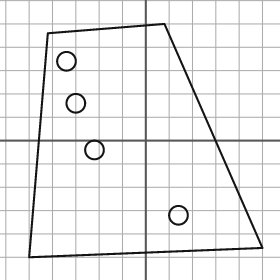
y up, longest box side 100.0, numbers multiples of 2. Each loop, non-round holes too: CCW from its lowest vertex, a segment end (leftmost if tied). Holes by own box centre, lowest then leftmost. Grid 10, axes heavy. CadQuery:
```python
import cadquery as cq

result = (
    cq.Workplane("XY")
    .moveTo(-50.0, -50.0)
    .lineTo(50.0, -46.0)
    .lineTo(8.0, 50.0)
    .lineTo(-42.0, 46.0)
    .close()
    .moveTo(14.0, -32.0)
    .circle(4.0)
    .moveTo(-22.0, -4.0)
    .circle(4.0)
    .moveTo(-30.0, 16.0)
    .circle(4.0)
    .moveTo(-34.0, 34.0)
    .circle(4.0)
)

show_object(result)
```